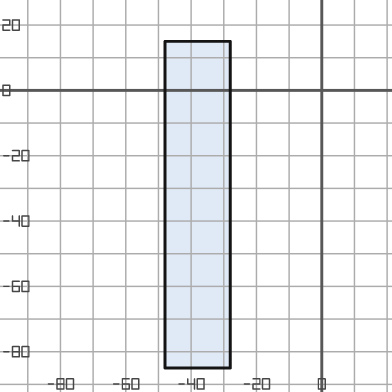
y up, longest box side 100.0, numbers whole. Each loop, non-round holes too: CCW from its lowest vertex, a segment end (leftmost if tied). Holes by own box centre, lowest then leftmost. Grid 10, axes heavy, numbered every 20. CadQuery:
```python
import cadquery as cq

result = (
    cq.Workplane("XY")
    .moveTo(-48.0, -85.0)
    .lineTo(-28.0, -85.0)
    .lineTo(-28.0, 15.0)
    .lineTo(-48.0, 15.0)
    .close()
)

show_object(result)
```